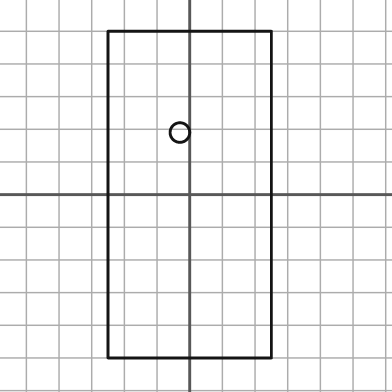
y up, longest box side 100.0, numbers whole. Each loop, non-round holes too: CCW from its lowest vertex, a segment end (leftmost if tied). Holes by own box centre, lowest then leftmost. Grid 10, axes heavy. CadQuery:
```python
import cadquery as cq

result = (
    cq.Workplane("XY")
    .moveTo(-25.0, -50.0)
    .lineTo(25.0, -50.0)
    .lineTo(25.0, 50.0)
    .lineTo(-25.0, 50.0)
    .close()
    .moveTo(-3.0, 19.0)
    .circle(3.0)
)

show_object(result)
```